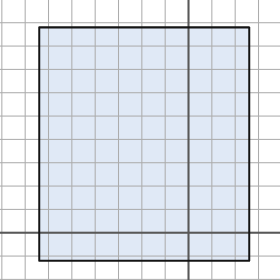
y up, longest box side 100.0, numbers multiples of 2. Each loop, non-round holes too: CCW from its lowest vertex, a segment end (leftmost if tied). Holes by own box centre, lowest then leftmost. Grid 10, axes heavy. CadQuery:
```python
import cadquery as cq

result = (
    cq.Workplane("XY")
    .moveTo(-64.0, -12.0)
    .lineTo(26.0, -12.0)
    .lineTo(26.0, 88.0)
    .lineTo(-64.0, 88.0)
    .close()
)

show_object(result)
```